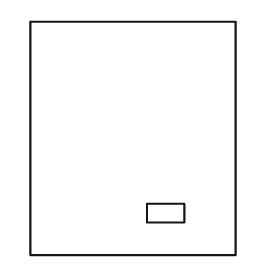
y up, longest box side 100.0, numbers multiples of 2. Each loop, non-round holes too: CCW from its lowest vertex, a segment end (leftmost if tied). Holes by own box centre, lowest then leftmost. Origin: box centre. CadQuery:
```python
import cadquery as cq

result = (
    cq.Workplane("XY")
    .moveTo(-44.0, -50.0)
    .lineTo(44.0, -50.0)
    .lineTo(44.0, 50.0)
    .lineTo(-44.0, 50.0)
    .close()
    .moveTo(6.0, -36.0)
    .lineTo(22.0, -36.0)
    .lineTo(22.0, -28.0)
    .lineTo(6.0, -28.0)
    .close()
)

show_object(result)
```